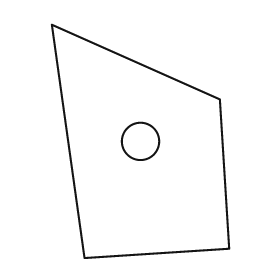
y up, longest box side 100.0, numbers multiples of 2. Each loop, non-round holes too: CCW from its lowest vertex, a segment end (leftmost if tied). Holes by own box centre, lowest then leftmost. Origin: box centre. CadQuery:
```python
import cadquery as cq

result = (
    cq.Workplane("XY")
    .moveTo(-24.0, -50.0)
    .lineTo(38.0, -46.0)
    .lineTo(34.0, 18.0)
    .lineTo(-38.0, 50.0)
    .close()
    .moveTo(0.0, 0.0)
    .circle(8.0)
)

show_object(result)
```